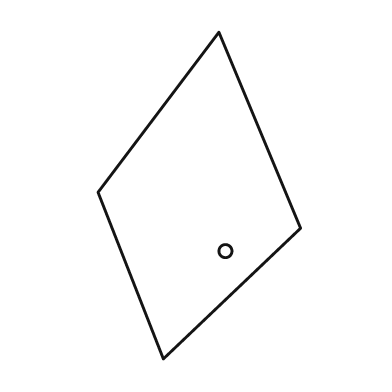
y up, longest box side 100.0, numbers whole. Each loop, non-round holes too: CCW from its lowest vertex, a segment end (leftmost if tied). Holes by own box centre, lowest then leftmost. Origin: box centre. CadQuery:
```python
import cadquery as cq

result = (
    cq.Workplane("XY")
    .moveTo(-11.0, -50.0)
    .lineTo(31.0, -10.0)
    .lineTo(6.0, 50.0)
    .lineTo(-31.0, 1.0)
    .close()
    .moveTo(8.0, -17.0)
    .circle(2.0)
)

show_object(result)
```